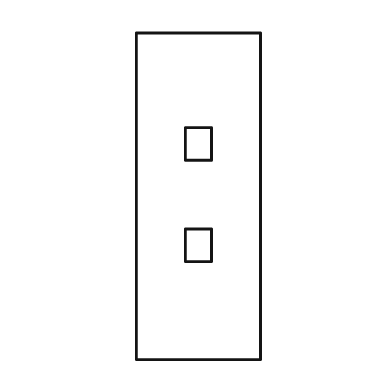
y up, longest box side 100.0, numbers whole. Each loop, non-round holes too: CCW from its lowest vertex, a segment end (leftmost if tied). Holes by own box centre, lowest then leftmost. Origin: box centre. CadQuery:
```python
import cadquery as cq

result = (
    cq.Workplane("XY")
    .moveTo(-19.0, -50.0)
    .lineTo(19.0, -50.0)
    .lineTo(19.0, 50.0)
    .lineTo(-19.0, 50.0)
    .close()
    .moveTo(-4.0, -20.0)
    .lineTo(4.0, -20.0)
    .lineTo(4.0, -10.0)
    .lineTo(-4.0, -10.0)
    .close()
    .moveTo(-4.0, 11.0)
    .lineTo(4.0, 11.0)
    .lineTo(4.0, 21.0)
    .lineTo(-4.0, 21.0)
    .close()
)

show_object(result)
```